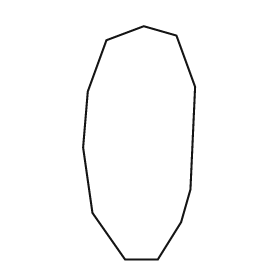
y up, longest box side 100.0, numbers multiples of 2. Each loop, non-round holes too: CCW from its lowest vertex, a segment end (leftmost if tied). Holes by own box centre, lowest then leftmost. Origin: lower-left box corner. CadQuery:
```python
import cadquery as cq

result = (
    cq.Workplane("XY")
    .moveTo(18.0, 0.0)
    .lineTo(32.0, 0.0)
    .lineTo(42.0, 16.0)
    .lineTo(46.0, 30.0)
    .lineTo(48.0, 74.0)
    .lineTo(40.0, 96.0)
    .lineTo(26.0, 100.0)
    .lineTo(10.0, 94.0)
    .lineTo(2.0, 72.0)
    .lineTo(0.0, 48.0)
    .lineTo(4.0, 20.0)
    .close()
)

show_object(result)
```